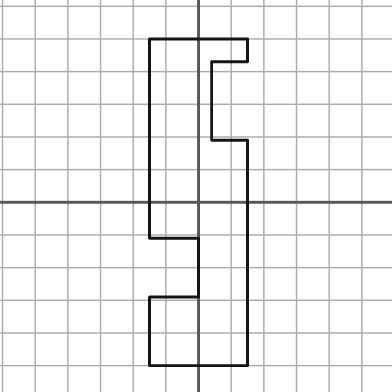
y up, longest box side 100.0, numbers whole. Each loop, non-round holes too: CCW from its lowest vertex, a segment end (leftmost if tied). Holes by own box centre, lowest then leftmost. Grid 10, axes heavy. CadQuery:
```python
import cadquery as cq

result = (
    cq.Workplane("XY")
    .moveTo(-15.0, -50.0)
    .lineTo(15.0, -50.0)
    .lineTo(15.0, 19.0)
    .lineTo(4.0, 19.0)
    .lineTo(4.0, 43.0)
    .lineTo(15.0, 43.0)
    .lineTo(15.0, 50.0)
    .lineTo(-15.0, 50.0)
    .lineTo(-15.0, -11.0)
    .lineTo(0.0, -11.0)
    .lineTo(0.0, -29.0)
    .lineTo(-15.0, -29.0)
    .close()
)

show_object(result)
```